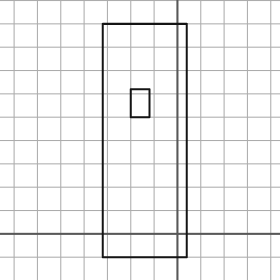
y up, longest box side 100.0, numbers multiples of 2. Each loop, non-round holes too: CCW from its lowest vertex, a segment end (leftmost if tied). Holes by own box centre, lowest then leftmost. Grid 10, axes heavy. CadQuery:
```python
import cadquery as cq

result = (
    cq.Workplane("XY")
    .moveTo(-32.0, -10.0)
    .lineTo(4.0, -10.0)
    .lineTo(4.0, 90.0)
    .lineTo(-32.0, 90.0)
    .close()
    .moveTo(-20.0, 50.0)
    .lineTo(-12.0, 50.0)
    .lineTo(-12.0, 62.0)
    .lineTo(-20.0, 62.0)
    .close()
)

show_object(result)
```